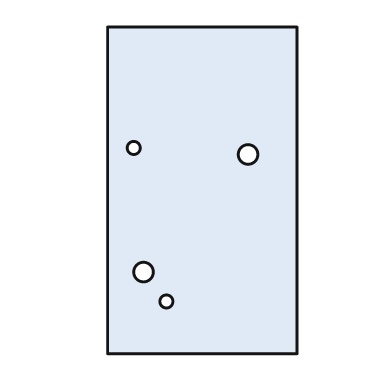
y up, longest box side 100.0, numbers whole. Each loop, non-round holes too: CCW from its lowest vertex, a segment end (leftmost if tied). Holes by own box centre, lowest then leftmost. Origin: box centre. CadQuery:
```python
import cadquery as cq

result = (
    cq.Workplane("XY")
    .moveTo(-29.0, -50.0)
    .lineTo(29.0, -50.0)
    .lineTo(29.0, 50.0)
    .lineTo(-29.0, 50.0)
    .close()
    .moveTo(-11.0, -34.0)
    .circle(2.0)
    .moveTo(-18.0, -25.0)
    .circle(3.0)
    .moveTo(14.0, 11.0)
    .circle(3.0)
    .moveTo(-21.0, 13.0)
    .circle(2.0)
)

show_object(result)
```